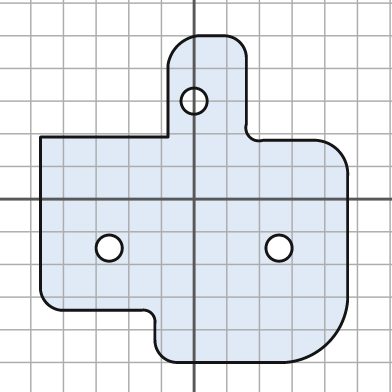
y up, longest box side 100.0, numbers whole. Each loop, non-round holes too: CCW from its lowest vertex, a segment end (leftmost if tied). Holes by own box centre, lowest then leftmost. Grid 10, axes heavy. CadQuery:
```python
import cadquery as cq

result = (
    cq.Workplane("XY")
    .moveTo(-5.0, -50.0)
    .lineTo(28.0, -50.0)
    .threePointArc((41.0, -44.0), (47.0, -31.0))
    .lineTo(47.0, 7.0)
    .threePointArc((44.0, 15.0), (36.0, 18.0))
    .lineTo(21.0, 18.0)
    .threePointArc((17.0, 19.0), (16.0, 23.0))
    .lineTo(16.0, 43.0)
    .threePointArc((14.0, 48.0), (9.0, 50.0))
    .lineTo(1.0, 50.0)
    .threePointArc((-5.0, 47.0), (-8.0, 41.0))
    .lineTo(-8.0, 19.0)
    .lineTo(-47.0, 19.0)
    .lineTo(-47.0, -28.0)
    .threePointArc((-45.0, -32.0), (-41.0, -34.0))
    .lineTo(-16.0, -34.0)
    .threePointArc((-13.0, -35.0), (-12.0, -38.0))
    .lineTo(-12.0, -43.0)
    .threePointArc((-10.0, -48.0), (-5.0, -50.0))
    .close()
    .moveTo(-26.0, -15.0)
    .circle(4.0)
    .moveTo(26.0, -15.0)
    .circle(4.0)
    .moveTo(0.0, 30.0)
    .circle(4.0)
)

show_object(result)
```